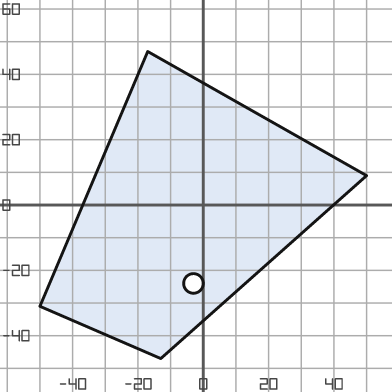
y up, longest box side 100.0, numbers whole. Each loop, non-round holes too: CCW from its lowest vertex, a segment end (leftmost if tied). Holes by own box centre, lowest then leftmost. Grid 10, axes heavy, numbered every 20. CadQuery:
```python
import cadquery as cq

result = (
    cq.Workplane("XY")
    .moveTo(-13.0, -47.0)
    .lineTo(50.0, 9.0)
    .lineTo(-17.0, 47.0)
    .lineTo(-50.0, -31.0)
    .close()
    .moveTo(-3.0, -24.0)
    .circle(3.0)
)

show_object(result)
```